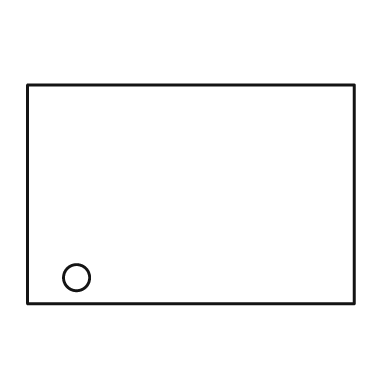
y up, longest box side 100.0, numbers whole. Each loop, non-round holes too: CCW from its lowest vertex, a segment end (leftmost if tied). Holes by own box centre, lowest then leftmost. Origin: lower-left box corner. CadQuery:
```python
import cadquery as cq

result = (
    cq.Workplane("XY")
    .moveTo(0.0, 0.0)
    .lineTo(100.0, 0.0)
    .lineTo(100.0, 67.0)
    .lineTo(0.0, 67.0)
    .close()
    .moveTo(15.0, 8.0)
    .circle(4.0)
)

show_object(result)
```